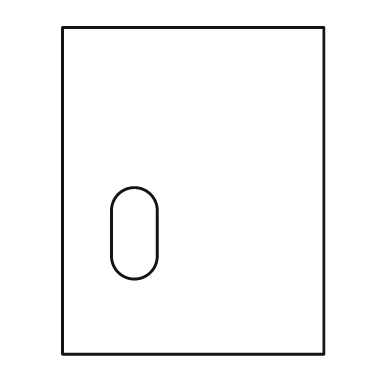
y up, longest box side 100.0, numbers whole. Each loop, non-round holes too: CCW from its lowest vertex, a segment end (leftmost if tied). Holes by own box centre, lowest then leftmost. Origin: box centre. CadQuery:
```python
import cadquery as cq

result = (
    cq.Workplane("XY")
    .moveTo(-40.0, -50.0)
    .lineTo(40.0, -50.0)
    .lineTo(40.0, 50.0)
    .lineTo(-40.0, 50.0)
    .close()
    .moveTo(-25.0, -20.0)
    .threePointArc((-18.0, -27.0), (-11.0, -20.0))
    .lineTo(-11.0, -6.0)
    .threePointArc((-18.0, 1.0), (-25.0, -6.0))
    .close()
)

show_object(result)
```